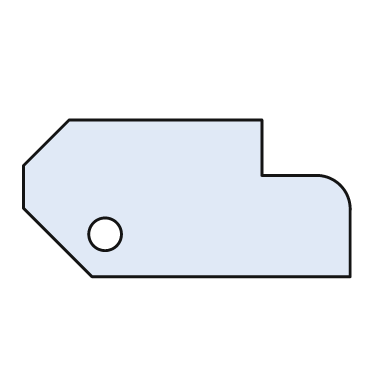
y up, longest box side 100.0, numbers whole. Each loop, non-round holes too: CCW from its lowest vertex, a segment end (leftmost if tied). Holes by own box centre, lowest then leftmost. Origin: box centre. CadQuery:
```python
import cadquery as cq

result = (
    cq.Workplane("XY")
    .moveTo(-29.0, -24.0)
    .lineTo(50.0, -24.0)
    .lineTo(50.0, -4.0)
    .threePointArc((47.0, 4.0), (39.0, 7.0))
    .lineTo(23.0, 7.0)
    .lineTo(23.0, 24.0)
    .lineTo(-36.0, 24.0)
    .lineTo(-50.0, 10.0)
    .lineTo(-50.0, -3.0)
    .close()
    .moveTo(-25.0, -11.0)
    .circle(5.0)
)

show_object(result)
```